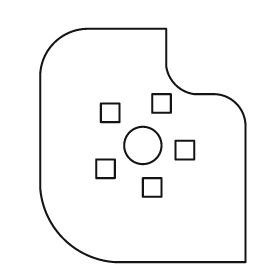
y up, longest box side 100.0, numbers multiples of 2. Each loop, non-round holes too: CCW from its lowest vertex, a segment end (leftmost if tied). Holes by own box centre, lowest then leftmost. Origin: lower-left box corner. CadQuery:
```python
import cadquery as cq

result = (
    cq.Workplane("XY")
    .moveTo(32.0, 0.0)
    .lineTo(88.0, 0.0)
    .lineTo(88.0, 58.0)
    .threePointArc((84.0, 68.0), (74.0, 72.0))
    .lineTo(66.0, 72.0)
    .threePointArc((58.0, 76.0), (54.0, 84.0))
    .lineTo(54.0, 100.0)
    .lineTo(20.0, 100.0)
    .threePointArc((6.0, 94.0), (0.0, 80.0))
    .lineTo(0.0, 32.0)
    .threePointArc((10.0, 10.0), (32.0, 0.0))
    .close()
    .moveTo(44.0, 28.0)
    .lineTo(52.0, 28.0)
    .lineTo(52.0, 36.0)
    .lineTo(44.0, 36.0)
    .close()
    .moveTo(24.0, 36.0)
    .lineTo(32.0, 36.0)
    .lineTo(32.0, 44.0)
    .lineTo(24.0, 44.0)
    .close()
    .moveTo(58.0, 44.0)
    .lineTo(66.0, 44.0)
    .lineTo(66.0, 52.0)
    .lineTo(58.0, 52.0)
    .close()
    .moveTo(44.0, 50.0)
    .circle(8.0)
    .moveTo(26.0, 60.0)
    .lineTo(34.0, 60.0)
    .lineTo(34.0, 68.0)
    .lineTo(26.0, 68.0)
    .close()
    .moveTo(48.0, 64.0)
    .lineTo(56.0, 64.0)
    .lineTo(56.0, 72.0)
    .lineTo(48.0, 72.0)
    .close()
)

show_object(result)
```